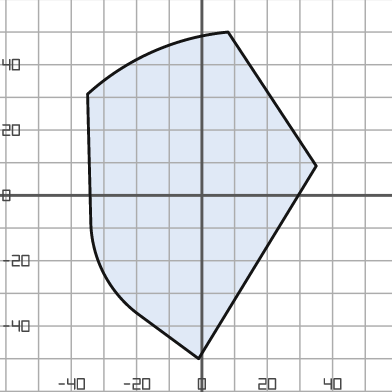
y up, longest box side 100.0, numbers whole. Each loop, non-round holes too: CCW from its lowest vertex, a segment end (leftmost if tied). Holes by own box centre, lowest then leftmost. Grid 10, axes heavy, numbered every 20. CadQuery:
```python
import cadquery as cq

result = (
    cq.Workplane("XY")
    .moveTo(-1.0, -50.0)
    .lineTo(35.0, 9.0)
    .lineTo(8.0, 50.0)
    .threePointArc((-15.0, 44.0), (-35.0, 31.0))
    .lineTo(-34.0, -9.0)
    .threePointArc((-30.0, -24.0), (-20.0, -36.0))
    .close()
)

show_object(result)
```